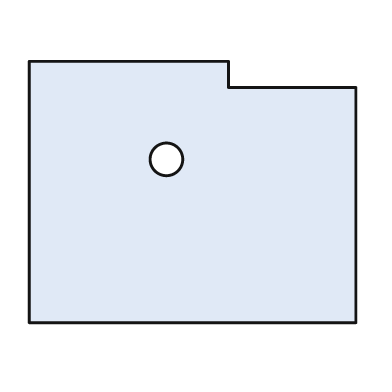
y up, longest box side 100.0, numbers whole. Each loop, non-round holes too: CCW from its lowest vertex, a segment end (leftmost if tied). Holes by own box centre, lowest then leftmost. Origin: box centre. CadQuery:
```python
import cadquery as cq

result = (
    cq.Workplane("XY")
    .moveTo(-50.0, -40.0)
    .lineTo(50.0, -40.0)
    .lineTo(50.0, 32.0)
    .lineTo(11.0, 32.0)
    .lineTo(11.0, 40.0)
    .lineTo(-50.0, 40.0)
    .close()
    .moveTo(-8.0, 10.0)
    .circle(5.0)
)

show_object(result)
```